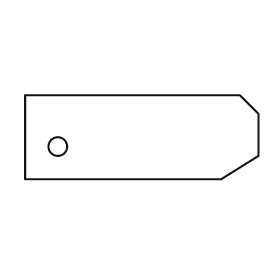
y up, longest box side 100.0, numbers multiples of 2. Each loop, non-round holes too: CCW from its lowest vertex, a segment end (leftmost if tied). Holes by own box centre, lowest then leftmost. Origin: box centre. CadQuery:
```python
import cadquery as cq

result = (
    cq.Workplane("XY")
    .moveTo(-50.0, -18.0)
    .lineTo(34.0, -18.0)
    .lineTo(50.0, -8.0)
    .lineTo(50.0, 10.0)
    .lineTo(42.0, 18.0)
    .lineTo(-50.0, 18.0)
    .close()
    .moveTo(-36.0, -4.0)
    .circle(4.0)
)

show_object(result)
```